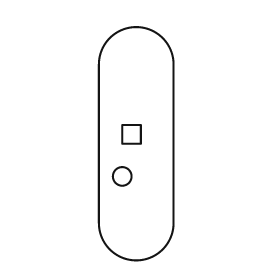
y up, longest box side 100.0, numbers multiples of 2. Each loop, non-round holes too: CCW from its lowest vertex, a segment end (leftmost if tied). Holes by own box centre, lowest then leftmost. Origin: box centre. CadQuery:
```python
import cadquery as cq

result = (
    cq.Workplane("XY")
    .moveTo(-16.0, -34.0)
    .threePointArc((0.0, -50.0), (16.0, -34.0))
    .lineTo(16.0, 34.0)
    .threePointArc((0.0, 50.0), (-16.0, 34.0))
    .close()
    .moveTo(-6.0, -14.0)
    .circle(4.0)
    .moveTo(-6.0, 0.0)
    .lineTo(2.0, 0.0)
    .lineTo(2.0, 8.0)
    .lineTo(-6.0, 8.0)
    .close()
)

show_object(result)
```